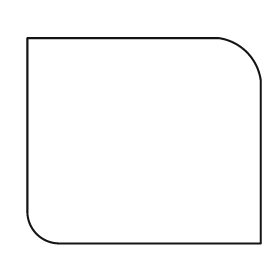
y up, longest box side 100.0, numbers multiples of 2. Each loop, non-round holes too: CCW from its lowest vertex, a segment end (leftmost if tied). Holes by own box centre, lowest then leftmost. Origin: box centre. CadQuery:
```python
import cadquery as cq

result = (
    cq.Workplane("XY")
    .moveTo(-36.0, -44.0)
    .lineTo(50.0, -44.0)
    .lineTo(50.0, 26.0)
    .threePointArc((44.0, 38.0), (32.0, 44.0))
    .lineTo(-50.0, 44.0)
    .lineTo(-50.0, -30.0)
    .threePointArc((-46.0, -40.0), (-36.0, -44.0))
    .close()
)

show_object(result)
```